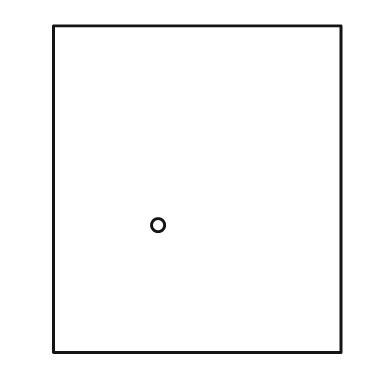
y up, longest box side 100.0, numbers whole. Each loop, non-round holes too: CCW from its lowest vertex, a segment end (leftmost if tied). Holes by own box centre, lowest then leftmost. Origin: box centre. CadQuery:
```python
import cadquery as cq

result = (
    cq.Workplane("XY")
    .moveTo(-44.0, -50.0)
    .lineTo(44.0, -50.0)
    .lineTo(44.0, 50.0)
    .lineTo(-44.0, 50.0)
    .close()
    .moveTo(-12.0, -11.0)
    .circle(2.0)
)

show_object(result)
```